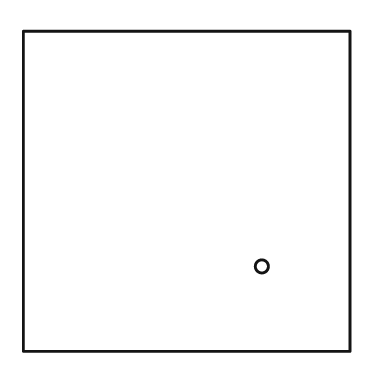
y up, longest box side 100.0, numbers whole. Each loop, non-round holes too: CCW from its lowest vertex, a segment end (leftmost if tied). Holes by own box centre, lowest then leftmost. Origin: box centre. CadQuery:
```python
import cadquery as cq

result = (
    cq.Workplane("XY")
    .moveTo(-50.0, -49.0)
    .lineTo(50.0, -49.0)
    .lineTo(50.0, 49.0)
    .lineTo(-50.0, 49.0)
    .close()
    .moveTo(23.0, -23.0)
    .circle(2.0)
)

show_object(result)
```